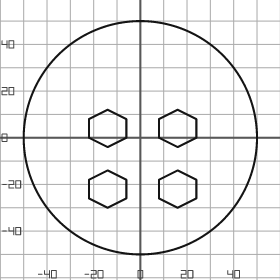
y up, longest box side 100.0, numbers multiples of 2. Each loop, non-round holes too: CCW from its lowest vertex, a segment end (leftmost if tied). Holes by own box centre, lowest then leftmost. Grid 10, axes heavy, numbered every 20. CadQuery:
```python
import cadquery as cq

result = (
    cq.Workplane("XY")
    .moveTo(0.0, 0.0)
    .circle(50.0)
    .moveTo(-14.0, -30.0)
    .lineTo(-6.0, -26.0)
    .lineTo(-6.0, -18.0)
    .lineTo(-14.0, -14.0)
    .lineTo(-22.0, -18.0)
    .lineTo(-22.0, -26.0)
    .close()
    .moveTo(16.0, -30.0)
    .lineTo(24.0, -26.0)
    .lineTo(24.0, -18.0)
    .lineTo(16.0, -14.0)
    .lineTo(8.0, -18.0)
    .lineTo(8.0, -26.0)
    .close()
    .moveTo(-14.0, -4.0)
    .lineTo(-6.0, 0.0)
    .lineTo(-6.0, 8.0)
    .lineTo(-14.0, 12.0)
    .lineTo(-22.0, 8.0)
    .lineTo(-22.0, 0.0)
    .close()
    .moveTo(16.0, -4.0)
    .lineTo(24.0, 0.0)
    .lineTo(24.0, 8.0)
    .lineTo(16.0, 12.0)
    .lineTo(8.0, 8.0)
    .lineTo(8.0, 0.0)
    .close()
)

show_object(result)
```